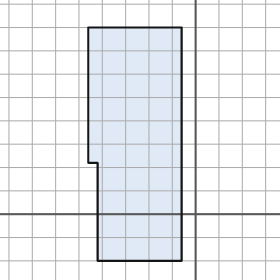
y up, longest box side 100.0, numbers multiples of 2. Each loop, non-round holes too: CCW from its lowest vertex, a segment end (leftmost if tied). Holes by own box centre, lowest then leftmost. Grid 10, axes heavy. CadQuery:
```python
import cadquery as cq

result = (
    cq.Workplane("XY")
    .moveTo(-42.0, -20.0)
    .lineTo(-6.0, -20.0)
    .lineTo(-6.0, 80.0)
    .lineTo(-46.0, 80.0)
    .lineTo(-46.0, 22.0)
    .lineTo(-42.0, 22.0)
    .close()
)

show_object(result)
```